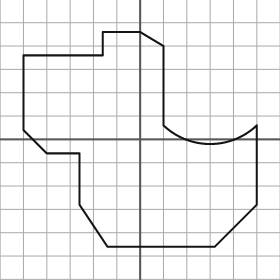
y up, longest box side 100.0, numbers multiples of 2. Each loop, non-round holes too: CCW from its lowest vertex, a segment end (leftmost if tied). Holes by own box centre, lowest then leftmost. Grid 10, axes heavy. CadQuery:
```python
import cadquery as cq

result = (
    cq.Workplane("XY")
    .moveTo(-14.0, -46.0)
    .lineTo(32.0, -46.0)
    .lineTo(50.0, -28.0)
    .lineTo(50.0, 6.0)
    .threePointArc((30.0, -2.0), (10.0, 6.0))
    .lineTo(10.0, 40.0)
    .lineTo(0.0, 46.0)
    .lineTo(-16.0, 46.0)
    .lineTo(-16.0, 36.0)
    .lineTo(-50.0, 36.0)
    .lineTo(-50.0, 4.0)
    .lineTo(-40.0, -6.0)
    .lineTo(-26.0, -6.0)
    .lineTo(-26.0, -28.0)
    .close()
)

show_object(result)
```